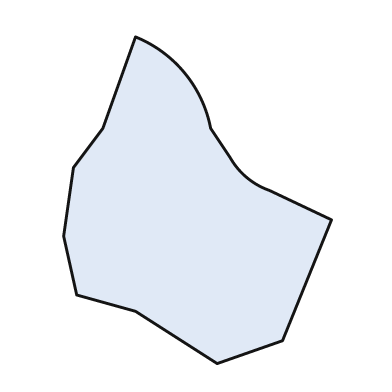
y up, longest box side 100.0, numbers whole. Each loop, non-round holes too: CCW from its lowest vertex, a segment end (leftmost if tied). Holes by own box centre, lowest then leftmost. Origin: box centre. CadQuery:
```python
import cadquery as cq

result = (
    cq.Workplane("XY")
    .moveTo(6.0, -50.0)
    .lineTo(26.0, -43.0)
    .lineTo(41.0, -6.0)
    .lineTo(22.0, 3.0)
    .threePointArc((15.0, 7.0), (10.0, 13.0))
    .lineTo(4.0, 22.0)
    .threePointArc((-4.0, 39.0), (-19.0, 50.0))
    .lineTo(-29.0, 22.0)
    .lineTo(-38.0, 10.0)
    .lineTo(-41.0, -11.0)
    .lineTo(-37.0, -29.0)
    .lineTo(-19.0, -34.0)
    .close()
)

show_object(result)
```